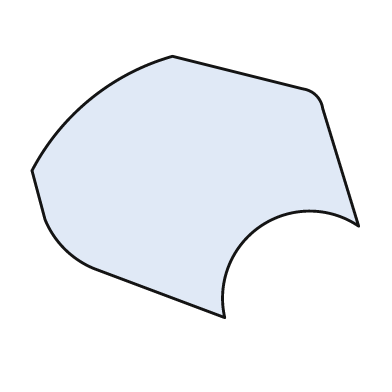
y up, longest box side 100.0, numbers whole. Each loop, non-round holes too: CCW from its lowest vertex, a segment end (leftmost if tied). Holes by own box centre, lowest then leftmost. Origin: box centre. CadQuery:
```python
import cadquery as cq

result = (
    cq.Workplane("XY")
    .moveTo(9.0, -40.0)
    .threePointArc((20.0, -12.0), (50.0, -12.0))
    .lineTo(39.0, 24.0)
    .threePointArc((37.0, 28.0), (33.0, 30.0))
    .lineTo(-7.0, 40.0)
    .threePointArc((-32.0, 27.0), (-50.0, 5.0))
    .lineTo(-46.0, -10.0)
    .threePointArc((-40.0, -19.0), (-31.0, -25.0))
    .close()
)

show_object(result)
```